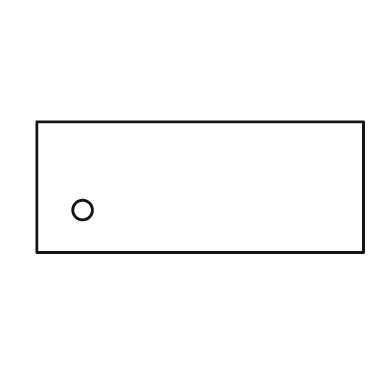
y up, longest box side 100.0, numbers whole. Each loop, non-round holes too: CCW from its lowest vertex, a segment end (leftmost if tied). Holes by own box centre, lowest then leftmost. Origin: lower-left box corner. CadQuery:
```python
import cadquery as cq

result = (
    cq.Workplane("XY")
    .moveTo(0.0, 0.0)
    .lineTo(100.0, 0.0)
    .lineTo(100.0, 40.0)
    .lineTo(0.0, 40.0)
    .close()
    .moveTo(14.0, 13.0)
    .circle(3.0)
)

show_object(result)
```